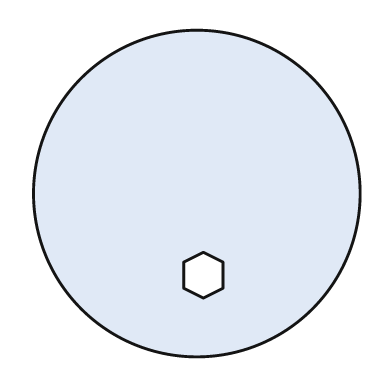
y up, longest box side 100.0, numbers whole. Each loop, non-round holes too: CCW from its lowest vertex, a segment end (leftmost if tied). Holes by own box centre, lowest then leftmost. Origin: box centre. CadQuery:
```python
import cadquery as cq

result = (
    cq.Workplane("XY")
    .moveTo(0.0, 0.0)
    .circle(50.0)
    .moveTo(2.0, -32.0)
    .lineTo(8.0, -29.0)
    .lineTo(8.0, -21.0)
    .lineTo(2.0, -18.0)
    .lineTo(-4.0, -21.0)
    .lineTo(-4.0, -29.0)
    .close()
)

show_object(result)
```